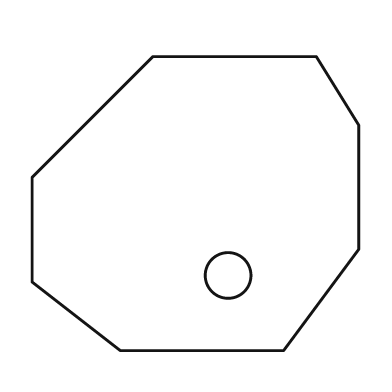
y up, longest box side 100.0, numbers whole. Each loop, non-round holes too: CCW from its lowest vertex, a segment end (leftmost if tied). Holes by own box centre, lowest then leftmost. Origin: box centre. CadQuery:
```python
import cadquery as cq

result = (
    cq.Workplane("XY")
    .moveTo(-23.0, -45.0)
    .lineTo(27.0, -45.0)
    .lineTo(50.0, -14.0)
    .lineTo(50.0, 24.0)
    .lineTo(37.0, 45.0)
    .lineTo(-13.0, 45.0)
    .lineTo(-50.0, 8.0)
    .lineTo(-50.0, -24.0)
    .close()
    .moveTo(10.0, -22.0)
    .circle(7.0)
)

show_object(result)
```